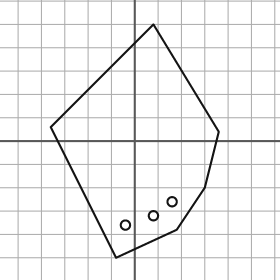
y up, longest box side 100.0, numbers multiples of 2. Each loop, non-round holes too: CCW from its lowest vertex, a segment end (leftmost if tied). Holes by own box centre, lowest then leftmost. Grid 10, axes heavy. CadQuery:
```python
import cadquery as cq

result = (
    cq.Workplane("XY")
    .moveTo(-8.0, -50.0)
    .lineTo(18.0, -38.0)
    .lineTo(30.0, -20.0)
    .lineTo(36.0, 4.0)
    .lineTo(8.0, 50.0)
    .lineTo(-36.0, 6.0)
    .close()
    .moveTo(-4.0, -36.0)
    .circle(2.0)
    .moveTo(8.0, -32.0)
    .circle(2.0)
    .moveTo(16.0, -26.0)
    .circle(2.0)
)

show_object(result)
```